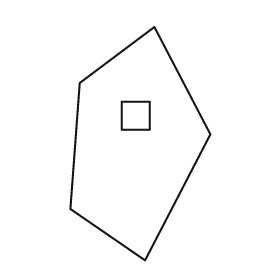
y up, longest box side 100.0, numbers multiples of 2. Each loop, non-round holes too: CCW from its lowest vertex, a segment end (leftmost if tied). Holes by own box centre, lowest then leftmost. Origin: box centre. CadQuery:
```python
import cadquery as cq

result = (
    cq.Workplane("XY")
    .moveTo(2.0, -50.0)
    .lineTo(30.0, 4.0)
    .lineTo(6.0, 50.0)
    .lineTo(-26.0, 26.0)
    .lineTo(-30.0, -28.0)
    .close()
    .moveTo(-8.0, 6.0)
    .lineTo(4.0, 6.0)
    .lineTo(4.0, 18.0)
    .lineTo(-8.0, 18.0)
    .close()
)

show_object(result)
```